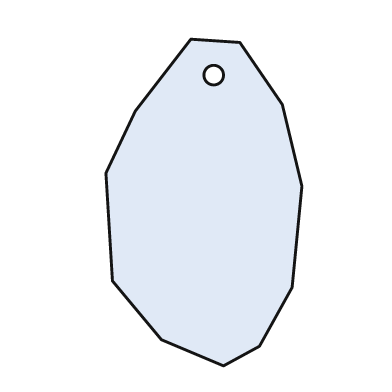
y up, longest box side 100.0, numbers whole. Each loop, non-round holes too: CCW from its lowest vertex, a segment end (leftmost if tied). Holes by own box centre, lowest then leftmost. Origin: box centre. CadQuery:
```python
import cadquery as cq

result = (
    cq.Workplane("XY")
    .moveTo(6.0, -50.0)
    .lineTo(17.0, -44.0)
    .lineTo(27.0, -26.0)
    .lineTo(30.0, 5.0)
    .lineTo(24.0, 30.0)
    .lineTo(11.0, 49.0)
    .lineTo(-4.0, 50.0)
    .lineTo(-21.0, 28.0)
    .lineTo(-30.0, 9.0)
    .lineTo(-28.0, -24.0)
    .lineTo(-13.0, -42.0)
    .close()
    .moveTo(3.0, 39.0)
    .circle(3.0)
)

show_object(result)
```